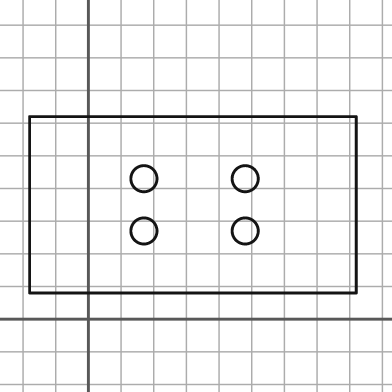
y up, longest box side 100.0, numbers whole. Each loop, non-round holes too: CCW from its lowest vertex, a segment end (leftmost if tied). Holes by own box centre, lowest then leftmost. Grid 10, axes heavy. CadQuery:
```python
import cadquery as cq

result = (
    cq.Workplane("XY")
    .moveTo(-18.0, 8.0)
    .lineTo(82.0, 8.0)
    .lineTo(82.0, 62.0)
    .lineTo(-18.0, 62.0)
    .close()
    .moveTo(17.0, 27.0)
    .circle(4.0)
    .moveTo(48.0, 27.0)
    .circle(4.0)
    .moveTo(17.0, 43.0)
    .circle(4.0)
    .moveTo(48.0, 43.0)
    .circle(4.0)
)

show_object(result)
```